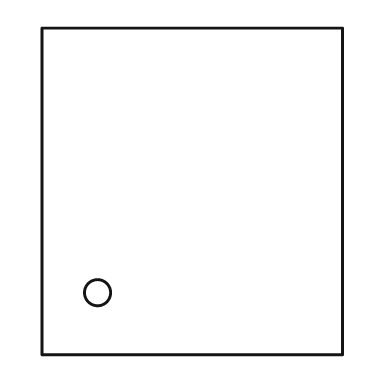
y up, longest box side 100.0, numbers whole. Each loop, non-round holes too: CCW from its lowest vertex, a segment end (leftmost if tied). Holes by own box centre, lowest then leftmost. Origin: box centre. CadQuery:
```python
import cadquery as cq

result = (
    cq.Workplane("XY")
    .moveTo(-46.0, -50.0)
    .lineTo(46.0, -50.0)
    .lineTo(46.0, 50.0)
    .lineTo(-46.0, 50.0)
    .close()
    .moveTo(-29.0, -31.0)
    .circle(4.0)
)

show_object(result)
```